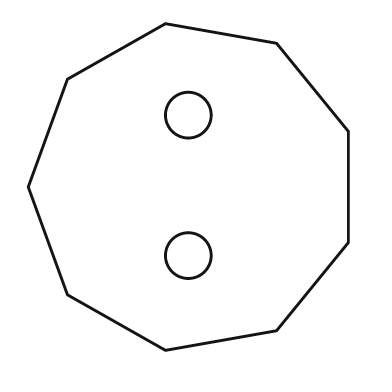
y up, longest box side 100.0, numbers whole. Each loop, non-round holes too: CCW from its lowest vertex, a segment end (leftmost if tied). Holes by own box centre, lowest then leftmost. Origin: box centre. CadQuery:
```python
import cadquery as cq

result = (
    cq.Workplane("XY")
    .moveTo(-7.0, -50.0)
    .lineTo(27.0, -44.0)
    .lineTo(49.0, -17.0)
    .lineTo(49.0, 17.0)
    .lineTo(27.0, 44.0)
    .lineTo(-7.0, 50.0)
    .lineTo(-37.0, 33.0)
    .lineTo(-49.0, 0.0)
    .lineTo(-37.0, -33.0)
    .close()
    .moveTo(0.0, -21.0)
    .circle(7.0)
    .moveTo(0.0, 22.0)
    .circle(7.0)
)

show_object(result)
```